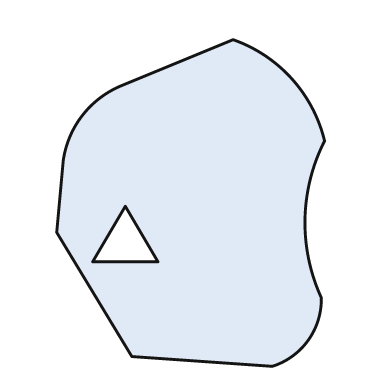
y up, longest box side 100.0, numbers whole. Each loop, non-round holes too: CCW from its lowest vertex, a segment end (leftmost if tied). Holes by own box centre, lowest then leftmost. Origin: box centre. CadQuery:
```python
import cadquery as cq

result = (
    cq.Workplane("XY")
    .moveTo(25.0, -50.0)
    .threePointArc((36.0, -42.0), (40.0, -29.0))
    .threePointArc((35.0, -5.0), (41.0, 19.0))
    .threePointArc((31.0, 38.0), (13.0, 50.0))
    .lineTo(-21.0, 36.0)
    .threePointArc((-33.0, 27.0), (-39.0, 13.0))
    .lineTo(-41.0, -9.0)
    .lineTo(-18.0, -47.0)
    .close()
    .moveTo(-30.0, -18.0)
    .lineTo(-10.0, -18.0)
    .lineTo(-20.0, -1.0)
    .close()
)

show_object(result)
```